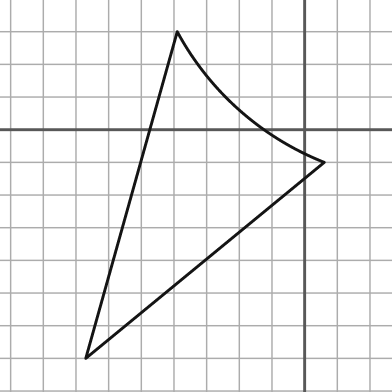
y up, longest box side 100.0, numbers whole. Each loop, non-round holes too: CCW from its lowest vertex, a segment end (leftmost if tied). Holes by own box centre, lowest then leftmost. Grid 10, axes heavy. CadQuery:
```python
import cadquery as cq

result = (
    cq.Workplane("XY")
    .moveTo(-67.0, -70.0)
    .lineTo(6.0, -10.0)
    .threePointArc((-20.0, 6.0), (-39.0, 30.0))
    .close()
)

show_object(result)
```